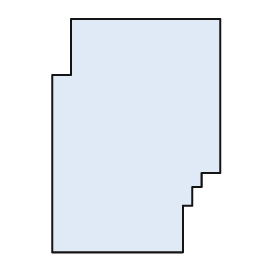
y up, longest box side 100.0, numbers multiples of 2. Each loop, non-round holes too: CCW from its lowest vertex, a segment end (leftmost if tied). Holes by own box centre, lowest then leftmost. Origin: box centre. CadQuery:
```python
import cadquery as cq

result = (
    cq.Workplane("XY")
    .moveTo(-36.0, -50.0)
    .lineTo(20.0, -50.0)
    .lineTo(20.0, -30.0)
    .lineTo(24.0, -30.0)
    .lineTo(24.0, -22.0)
    .lineTo(28.0, -22.0)
    .lineTo(28.0, -16.0)
    .lineTo(36.0, -16.0)
    .lineTo(36.0, 50.0)
    .lineTo(-28.0, 50.0)
    .lineTo(-28.0, 26.0)
    .lineTo(-36.0, 26.0)
    .close()
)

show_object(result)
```